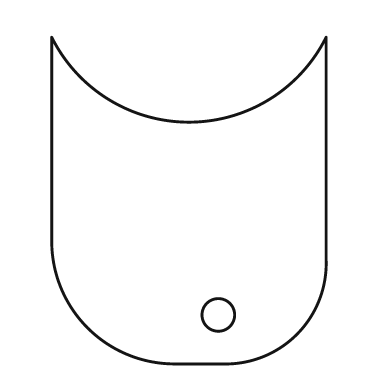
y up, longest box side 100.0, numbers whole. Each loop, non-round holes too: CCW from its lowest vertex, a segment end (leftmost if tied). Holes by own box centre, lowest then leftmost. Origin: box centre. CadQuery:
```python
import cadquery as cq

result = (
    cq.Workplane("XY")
    .moveTo(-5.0, -50.0)
    .lineTo(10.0, -50.0)
    .threePointArc((33.0, -41.0), (42.0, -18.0))
    .lineTo(42.0, 50.0)
    .threePointArc((0.0, 24.0), (-42.0, 50.0))
    .lineTo(-42.0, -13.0)
    .threePointArc((-31.0, -39.0), (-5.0, -50.0))
    .close()
    .moveTo(9.0, -35.0)
    .circle(5.0)
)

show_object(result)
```